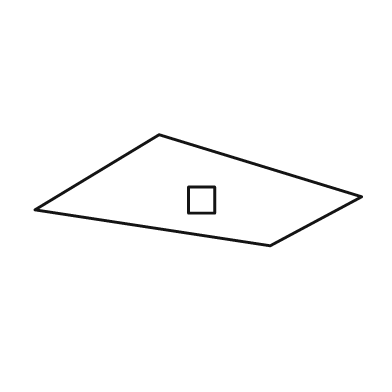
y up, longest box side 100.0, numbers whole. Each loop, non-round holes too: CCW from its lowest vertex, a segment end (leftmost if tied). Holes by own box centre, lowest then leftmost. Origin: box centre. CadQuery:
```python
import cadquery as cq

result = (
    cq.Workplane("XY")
    .moveTo(22.0, -17.0)
    .lineTo(50.0, -2.0)
    .lineTo(-12.0, 17.0)
    .lineTo(-50.0, -6.0)
    .close()
    .moveTo(-3.0, -7.0)
    .lineTo(5.0, -7.0)
    .lineTo(5.0, 1.0)
    .lineTo(-3.0, 1.0)
    .close()
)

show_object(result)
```